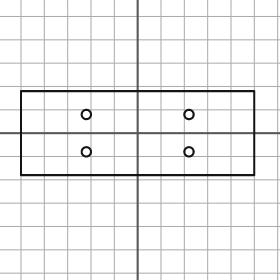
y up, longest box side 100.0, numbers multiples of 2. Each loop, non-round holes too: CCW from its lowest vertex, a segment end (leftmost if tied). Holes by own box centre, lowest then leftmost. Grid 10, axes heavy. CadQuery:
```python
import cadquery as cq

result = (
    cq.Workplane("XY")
    .moveTo(-50.0, -18.0)
    .lineTo(50.0, -18.0)
    .lineTo(50.0, 18.0)
    .lineTo(-50.0, 18.0)
    .close()
    .moveTo(-22.0, -8.0)
    .circle(2.0)
    .moveTo(22.0, -8.0)
    .circle(2.0)
    .moveTo(-22.0, 8.0)
    .circle(2.0)
    .moveTo(22.0, 8.0)
    .circle(2.0)
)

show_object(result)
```